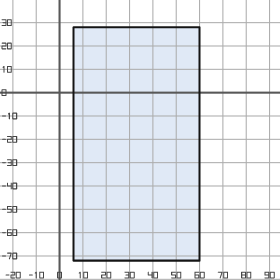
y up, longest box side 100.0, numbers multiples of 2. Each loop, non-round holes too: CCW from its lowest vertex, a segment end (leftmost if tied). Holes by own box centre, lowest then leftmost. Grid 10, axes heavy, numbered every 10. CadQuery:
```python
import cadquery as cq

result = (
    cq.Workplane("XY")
    .moveTo(6.0, -72.0)
    .lineTo(60.0, -72.0)
    .lineTo(60.0, 28.0)
    .lineTo(6.0, 28.0)
    .close()
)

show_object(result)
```